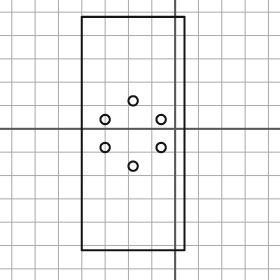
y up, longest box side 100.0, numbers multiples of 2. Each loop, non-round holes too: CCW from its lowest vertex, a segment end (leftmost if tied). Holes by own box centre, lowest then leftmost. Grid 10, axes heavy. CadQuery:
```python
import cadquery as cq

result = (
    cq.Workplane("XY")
    .moveTo(-40.0, -52.0)
    .lineTo(4.0, -52.0)
    .lineTo(4.0, 48.0)
    .lineTo(-40.0, 48.0)
    .close()
    .moveTo(-18.0, -16.0)
    .circle(2.0)
    .moveTo(-30.0, -8.0)
    .circle(2.0)
    .moveTo(-6.0, -8.0)
    .circle(2.0)
    .moveTo(-30.0, 4.0)
    .circle(2.0)
    .moveTo(-6.0, 4.0)
    .circle(2.0)
    .moveTo(-18.0, 12.0)
    .circle(2.0)
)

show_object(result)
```